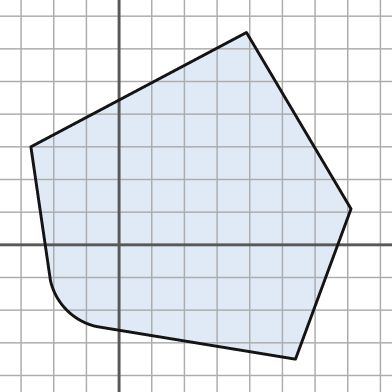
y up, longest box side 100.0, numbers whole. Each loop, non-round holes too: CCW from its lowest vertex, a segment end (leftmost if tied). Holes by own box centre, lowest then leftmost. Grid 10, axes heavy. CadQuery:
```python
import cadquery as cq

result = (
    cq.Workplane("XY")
    .moveTo(54.0, -35.0)
    .lineTo(71.0, 11.0)
    .lineTo(39.0, 65.0)
    .lineTo(-27.0, 30.0)
    .lineTo(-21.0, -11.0)
    .threePointArc((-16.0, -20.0), (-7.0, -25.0))
    .close()
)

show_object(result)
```